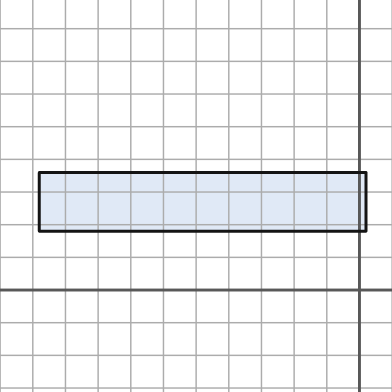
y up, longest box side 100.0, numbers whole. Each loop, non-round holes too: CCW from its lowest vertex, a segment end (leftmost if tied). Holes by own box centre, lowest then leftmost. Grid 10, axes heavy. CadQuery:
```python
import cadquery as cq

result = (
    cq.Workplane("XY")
    .moveTo(-98.0, 18.0)
    .lineTo(2.0, 18.0)
    .lineTo(2.0, 36.0)
    .lineTo(-98.0, 36.0)
    .close()
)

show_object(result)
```